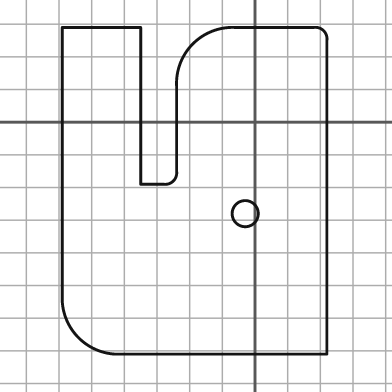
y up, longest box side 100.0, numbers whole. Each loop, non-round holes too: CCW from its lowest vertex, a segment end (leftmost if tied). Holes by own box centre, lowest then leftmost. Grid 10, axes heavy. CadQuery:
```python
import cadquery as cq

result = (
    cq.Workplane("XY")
    .moveTo(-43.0, -71.0)
    .lineTo(22.0, -71.0)
    .lineTo(22.0, 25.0)
    .threePointArc((21.0, 28.0), (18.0, 29.0))
    .lineTo(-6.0, 29.0)
    .threePointArc((-19.0, 24.0), (-24.0, 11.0))
    .lineTo(-24.0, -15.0)
    .threePointArc((-25.0, -18.0), (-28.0, -19.0))
    .lineTo(-35.0, -19.0)
    .lineTo(-35.0, 29.0)
    .lineTo(-59.0, 29.0)
    .lineTo(-59.0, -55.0)
    .threePointArc((-54.0, -66.0), (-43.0, -71.0))
    .close()
    .moveTo(-3.0, -28.0)
    .circle(4.0)
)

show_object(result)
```